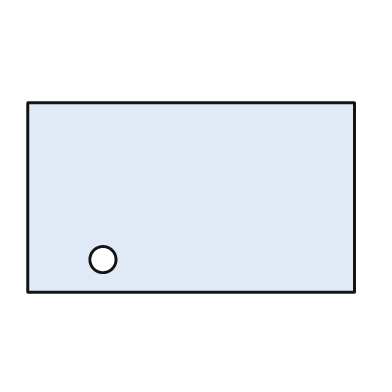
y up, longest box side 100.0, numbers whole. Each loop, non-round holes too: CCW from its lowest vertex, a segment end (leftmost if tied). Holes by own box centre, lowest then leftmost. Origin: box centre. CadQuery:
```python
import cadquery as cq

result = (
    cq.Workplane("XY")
    .moveTo(-50.0, -29.0)
    .lineTo(50.0, -29.0)
    .lineTo(50.0, 29.0)
    .lineTo(-50.0, 29.0)
    .close()
    .moveTo(-27.0, -19.0)
    .circle(4.0)
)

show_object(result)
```